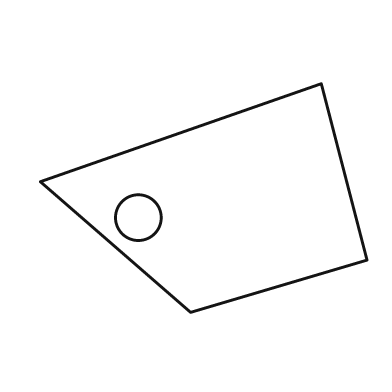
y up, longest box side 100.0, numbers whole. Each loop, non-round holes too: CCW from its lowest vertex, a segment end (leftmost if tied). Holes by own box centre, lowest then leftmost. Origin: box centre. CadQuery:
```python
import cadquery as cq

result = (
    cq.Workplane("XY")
    .moveTo(-4.0, -35.0)
    .lineTo(50.0, -19.0)
    .lineTo(36.0, 35.0)
    .lineTo(-50.0, 5.0)
    .close()
    .moveTo(-20.0, -6.0)
    .circle(7.0)
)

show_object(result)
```